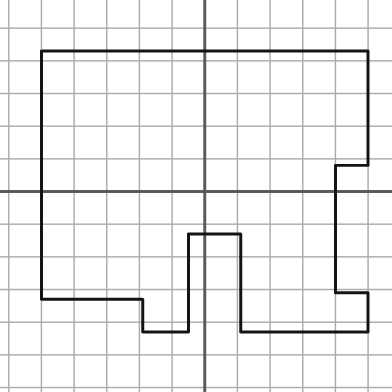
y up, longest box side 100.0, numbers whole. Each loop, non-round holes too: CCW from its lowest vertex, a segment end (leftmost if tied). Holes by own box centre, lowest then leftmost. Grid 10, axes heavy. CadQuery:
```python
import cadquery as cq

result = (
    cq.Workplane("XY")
    .moveTo(-19.0, -43.0)
    .lineTo(-5.0, -43.0)
    .lineTo(-5.0, -13.0)
    .lineTo(11.0, -13.0)
    .lineTo(11.0, -43.0)
    .lineTo(50.0, -43.0)
    .lineTo(50.0, -31.0)
    .lineTo(40.0, -31.0)
    .lineTo(40.0, 8.0)
    .lineTo(50.0, 8.0)
    .lineTo(50.0, 43.0)
    .lineTo(-50.0, 43.0)
    .lineTo(-50.0, -33.0)
    .lineTo(-19.0, -33.0)
    .close()
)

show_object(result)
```